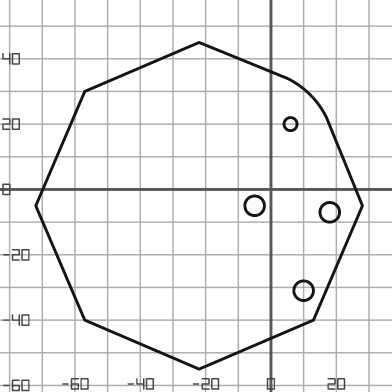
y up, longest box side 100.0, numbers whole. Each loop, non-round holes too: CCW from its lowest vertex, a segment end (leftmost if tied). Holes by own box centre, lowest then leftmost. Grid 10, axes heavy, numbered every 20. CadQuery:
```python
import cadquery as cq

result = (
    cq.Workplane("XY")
    .moveTo(-22.0, -55.0)
    .lineTo(13.0, -40.0)
    .lineTo(28.0, -5.0)
    .lineTo(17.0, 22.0)
    .threePointArc((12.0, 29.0), (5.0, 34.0))
    .lineTo(-22.0, 45.0)
    .lineTo(-57.0, 30.0)
    .lineTo(-72.0, -5.0)
    .lineTo(-57.0, -40.0)
    .close()
    .moveTo(10.0, -31.0)
    .circle(3.0)
    .moveTo(18.0, -7.0)
    .circle(3.0)
    .moveTo(-5.0, -5.0)
    .circle(3.0)
    .moveTo(6.0, 20.0)
    .circle(2.0)
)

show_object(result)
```